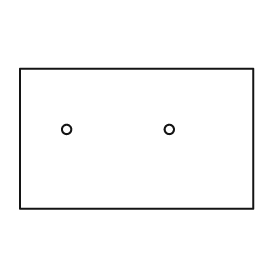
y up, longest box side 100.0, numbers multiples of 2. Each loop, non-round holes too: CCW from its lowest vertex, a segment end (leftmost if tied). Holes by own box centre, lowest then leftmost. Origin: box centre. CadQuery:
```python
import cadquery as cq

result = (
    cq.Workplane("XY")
    .moveTo(-50.0, -30.0)
    .lineTo(50.0, -30.0)
    .lineTo(50.0, 30.0)
    .lineTo(-50.0, 30.0)
    .close()
    .moveTo(-30.0, 4.0)
    .circle(2.0)
    .moveTo(14.0, 4.0)
    .circle(2.0)
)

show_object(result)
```